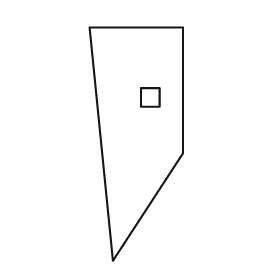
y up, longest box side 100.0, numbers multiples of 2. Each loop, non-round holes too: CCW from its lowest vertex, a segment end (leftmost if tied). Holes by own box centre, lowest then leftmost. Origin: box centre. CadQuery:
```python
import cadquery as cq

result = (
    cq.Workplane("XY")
    .moveTo(-10.0, -50.0)
    .lineTo(20.0, -4.0)
    .lineTo(20.0, 50.0)
    .lineTo(-20.0, 50.0)
    .close()
    .moveTo(2.0, 16.0)
    .lineTo(10.0, 16.0)
    .lineTo(10.0, 24.0)
    .lineTo(2.0, 24.0)
    .close()
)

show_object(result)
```